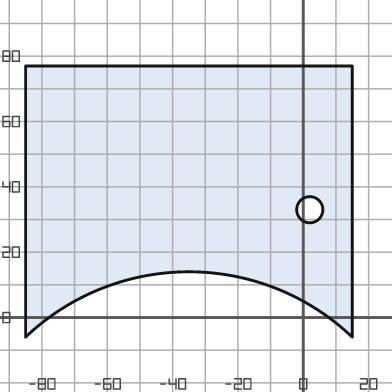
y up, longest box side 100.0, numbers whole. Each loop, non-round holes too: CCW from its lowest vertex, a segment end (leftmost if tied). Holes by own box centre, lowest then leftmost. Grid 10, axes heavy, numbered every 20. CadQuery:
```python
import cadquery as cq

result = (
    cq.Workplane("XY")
    .moveTo(-85.0, -6.0)
    .threePointArc((-35.0, 14.0), (15.0, -6.0))
    .lineTo(15.0, 77.0)
    .lineTo(-85.0, 77.0)
    .close()
    .moveTo(2.0, 33.0)
    .circle(4.0)
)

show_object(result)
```